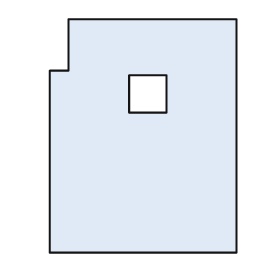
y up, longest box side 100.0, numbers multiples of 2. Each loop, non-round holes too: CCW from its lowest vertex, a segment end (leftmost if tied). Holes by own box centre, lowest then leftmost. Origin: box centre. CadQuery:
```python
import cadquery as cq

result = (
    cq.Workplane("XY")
    .moveTo(-40.0, -50.0)
    .lineTo(40.0, -50.0)
    .lineTo(40.0, 50.0)
    .lineTo(-32.0, 50.0)
    .lineTo(-32.0, 28.0)
    .lineTo(-40.0, 28.0)
    .close()
    .moveTo(-6.0, 10.0)
    .lineTo(10.0, 10.0)
    .lineTo(10.0, 26.0)
    .lineTo(-6.0, 26.0)
    .close()
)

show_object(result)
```